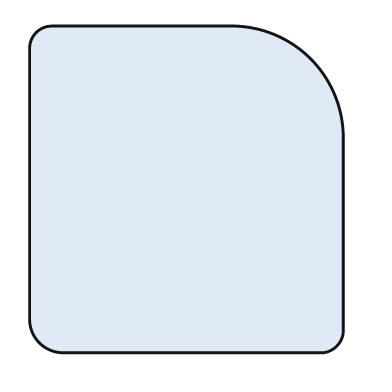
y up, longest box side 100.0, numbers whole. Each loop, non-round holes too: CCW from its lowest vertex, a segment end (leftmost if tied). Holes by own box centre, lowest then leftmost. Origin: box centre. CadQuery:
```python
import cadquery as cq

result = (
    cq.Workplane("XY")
    .moveTo(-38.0, -50.0)
    .lineTo(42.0, -50.0)
    .threePointArc((46.0, -48.0), (48.0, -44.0))
    .lineTo(48.0, 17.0)
    .threePointArc((38.0, 40.0), (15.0, 50.0))
    .lineTo(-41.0, 50.0)
    .threePointArc((-46.0, 48.0), (-48.0, 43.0))
    .lineTo(-48.0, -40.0)
    .threePointArc((-45.0, -47.0), (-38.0, -50.0))
    .close()
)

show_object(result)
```